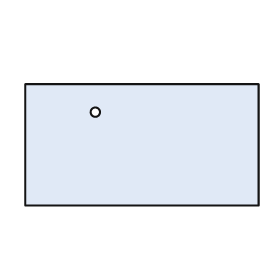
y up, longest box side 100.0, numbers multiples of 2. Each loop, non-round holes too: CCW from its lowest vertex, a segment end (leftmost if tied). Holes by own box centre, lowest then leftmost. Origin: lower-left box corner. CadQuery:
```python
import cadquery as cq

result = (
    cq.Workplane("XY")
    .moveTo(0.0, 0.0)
    .lineTo(100.0, 0.0)
    .lineTo(100.0, 52.0)
    .lineTo(0.0, 52.0)
    .close()
    .moveTo(30.0, 40.0)
    .circle(2.0)
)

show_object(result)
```